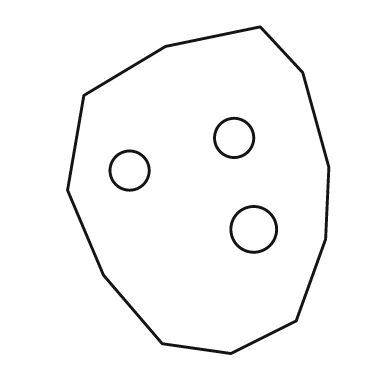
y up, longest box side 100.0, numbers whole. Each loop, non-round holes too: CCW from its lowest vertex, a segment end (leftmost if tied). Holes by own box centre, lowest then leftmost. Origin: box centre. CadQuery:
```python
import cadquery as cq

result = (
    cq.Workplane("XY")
    .moveTo(10.0, -50.0)
    .lineTo(30.0, -40.0)
    .lineTo(39.0, -15.0)
    .lineTo(40.0, 7.0)
    .lineTo(32.0, 36.0)
    .lineTo(19.0, 50.0)
    .lineTo(-10.0, 44.0)
    .lineTo(-35.0, 29.0)
    .lineTo(-40.0, 0.0)
    .lineTo(-29.0, -26.0)
    .lineTo(-11.0, -47.0)
    .close()
    .moveTo(17.0, -12.0)
    .circle(7.0)
    .moveTo(-21.0, 6.0)
    .circle(6.0)
    .moveTo(11.0, 16.0)
    .circle(6.0)
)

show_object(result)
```